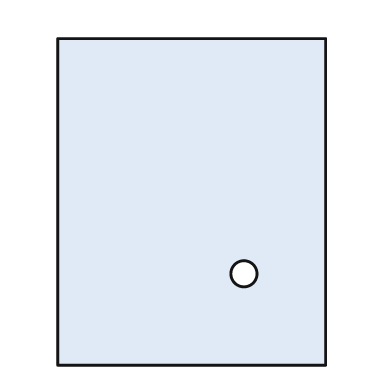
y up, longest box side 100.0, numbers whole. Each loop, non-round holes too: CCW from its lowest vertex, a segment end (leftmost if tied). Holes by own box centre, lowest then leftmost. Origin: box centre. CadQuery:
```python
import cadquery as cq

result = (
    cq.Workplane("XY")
    .moveTo(-41.0, -50.0)
    .lineTo(41.0, -50.0)
    .lineTo(41.0, 50.0)
    .lineTo(-41.0, 50.0)
    .close()
    .moveTo(16.0, -22.0)
    .circle(4.0)
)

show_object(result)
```